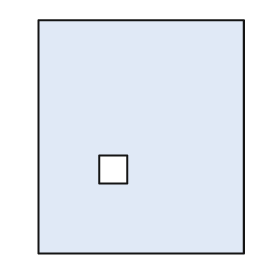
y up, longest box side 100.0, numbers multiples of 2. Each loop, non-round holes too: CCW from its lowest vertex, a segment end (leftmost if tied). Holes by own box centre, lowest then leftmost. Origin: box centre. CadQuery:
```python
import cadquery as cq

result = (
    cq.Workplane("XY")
    .moveTo(-44.0, -50.0)
    .lineTo(44.0, -50.0)
    .lineTo(44.0, 50.0)
    .lineTo(-44.0, 50.0)
    .close()
    .moveTo(-18.0, -20.0)
    .lineTo(-6.0, -20.0)
    .lineTo(-6.0, -8.0)
    .lineTo(-18.0, -8.0)
    .close()
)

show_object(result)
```